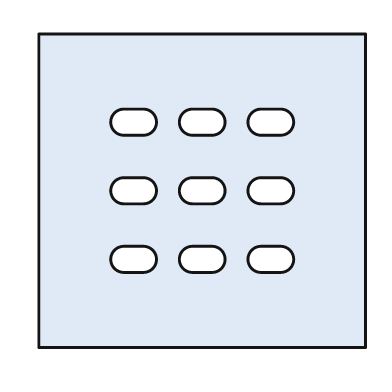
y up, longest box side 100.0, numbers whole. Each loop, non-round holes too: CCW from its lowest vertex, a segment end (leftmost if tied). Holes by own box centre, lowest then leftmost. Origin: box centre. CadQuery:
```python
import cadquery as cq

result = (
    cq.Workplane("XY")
    .moveTo(-50.0, -48.0)
    .lineTo(50.0, -48.0)
    .lineTo(50.0, 48.0)
    .lineTo(-50.0, 48.0)
    .close()
    .moveTo(-24.0, -25.0)
    .lineTo(-18.0, -25.0)
    .threePointArc((-14.0, -21.0), (-18.0, -17.0))
    .lineTo(-24.0, -17.0)
    .threePointArc((-28.0, -21.0), (-24.0, -25.0))
    .close()
    .moveTo(-3.0, -25.0)
    .lineTo(3.0, -25.0)
    .threePointArc((7.0, -21.0), (3.0, -17.0))
    .lineTo(-3.0, -17.0)
    .threePointArc((-7.0, -21.0), (-3.0, -25.0))
    .close()
    .moveTo(18.0, -25.0)
    .lineTo(24.0, -25.0)
    .threePointArc((28.0, -21.0), (24.0, -17.0))
    .lineTo(18.0, -17.0)
    .threePointArc((14.0, -21.0), (18.0, -25.0))
    .close()
    .moveTo(-24.0, -4.0)
    .lineTo(-18.0, -4.0)
    .threePointArc((-14.0, 0.0), (-18.0, 4.0))
    .lineTo(-24.0, 4.0)
    .threePointArc((-28.0, 0.0), (-24.0, -4.0))
    .close()
    .moveTo(-3.0, -4.0)
    .lineTo(3.0, -4.0)
    .threePointArc((7.0, 0.0), (3.0, 4.0))
    .lineTo(-3.0, 4.0)
    .threePointArc((-7.0, 0.0), (-3.0, -4.0))
    .close()
    .moveTo(18.0, -4.0)
    .lineTo(24.0, -4.0)
    .threePointArc((28.0, 0.0), (24.0, 4.0))
    .lineTo(18.0, 4.0)
    .threePointArc((14.0, 0.0), (18.0, -4.0))
    .close()
    .moveTo(-24.0, 17.0)
    .lineTo(-18.0, 17.0)
    .threePointArc((-14.0, 21.0), (-18.0, 25.0))
    .lineTo(-24.0, 25.0)
    .threePointArc((-28.0, 21.0), (-24.0, 17.0))
    .close()
    .moveTo(-3.0, 17.0)
    .lineTo(3.0, 17.0)
    .threePointArc((7.0, 21.0), (3.0, 25.0))
    .lineTo(-3.0, 25.0)
    .threePointArc((-7.0, 21.0), (-3.0, 17.0))
    .close()
    .moveTo(18.0, 17.0)
    .lineTo(24.0, 17.0)
    .threePointArc((28.0, 21.0), (24.0, 25.0))
    .lineTo(18.0, 25.0)
    .threePointArc((14.0, 21.0), (18.0, 17.0))
    .close()
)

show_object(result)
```